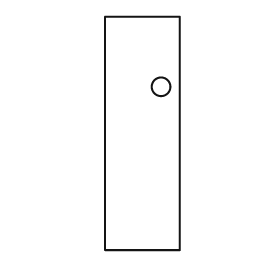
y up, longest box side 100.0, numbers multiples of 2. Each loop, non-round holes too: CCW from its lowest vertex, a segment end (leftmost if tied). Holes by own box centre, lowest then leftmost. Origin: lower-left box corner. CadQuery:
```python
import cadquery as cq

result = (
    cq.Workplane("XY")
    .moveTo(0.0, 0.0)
    .lineTo(32.0, 0.0)
    .lineTo(32.0, 100.0)
    .lineTo(0.0, 100.0)
    .close()
    .moveTo(24.0, 70.0)
    .circle(4.0)
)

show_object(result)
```